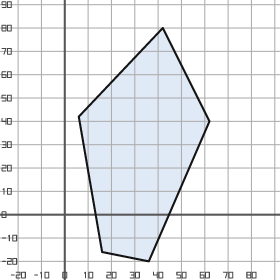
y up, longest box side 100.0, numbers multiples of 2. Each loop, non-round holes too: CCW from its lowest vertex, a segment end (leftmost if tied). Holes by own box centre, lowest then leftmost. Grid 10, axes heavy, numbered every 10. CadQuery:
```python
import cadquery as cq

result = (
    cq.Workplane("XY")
    .moveTo(36.0, -20.0)
    .lineTo(62.0, 40.0)
    .lineTo(42.0, 80.0)
    .lineTo(6.0, 42.0)
    .lineTo(16.0, -16.0)
    .close()
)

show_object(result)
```